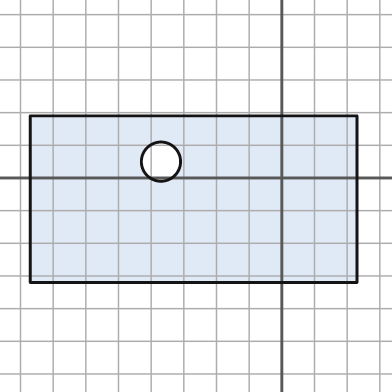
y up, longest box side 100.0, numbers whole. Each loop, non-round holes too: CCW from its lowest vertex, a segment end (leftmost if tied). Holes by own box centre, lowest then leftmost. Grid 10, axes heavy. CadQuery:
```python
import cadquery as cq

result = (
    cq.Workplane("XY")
    .moveTo(-77.0, -32.0)
    .lineTo(23.0, -32.0)
    .lineTo(23.0, 19.0)
    .lineTo(-77.0, 19.0)
    .close()
    .moveTo(-37.0, 5.0)
    .circle(6.0)
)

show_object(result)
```